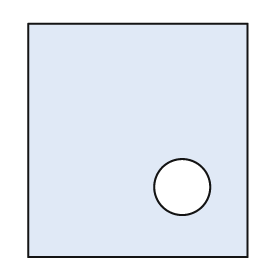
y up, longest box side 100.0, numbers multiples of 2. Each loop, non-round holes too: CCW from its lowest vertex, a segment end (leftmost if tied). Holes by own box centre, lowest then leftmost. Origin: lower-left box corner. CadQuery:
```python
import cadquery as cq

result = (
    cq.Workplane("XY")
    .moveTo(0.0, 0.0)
    .lineTo(94.0, 0.0)
    .lineTo(94.0, 100.0)
    .lineTo(0.0, 100.0)
    .close()
    .moveTo(66.0, 30.0)
    .circle(12.0)
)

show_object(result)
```